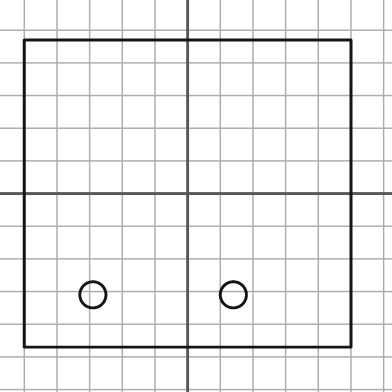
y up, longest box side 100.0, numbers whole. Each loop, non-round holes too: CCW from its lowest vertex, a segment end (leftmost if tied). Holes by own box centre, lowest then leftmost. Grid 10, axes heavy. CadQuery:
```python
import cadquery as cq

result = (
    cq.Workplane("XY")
    .moveTo(-50.0, -47.0)
    .lineTo(50.0, -47.0)
    .lineTo(50.0, 47.0)
    .lineTo(-50.0, 47.0)
    .close()
    .moveTo(-29.0, -31.0)
    .circle(4.0)
    .moveTo(14.0, -31.0)
    .circle(4.0)
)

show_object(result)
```